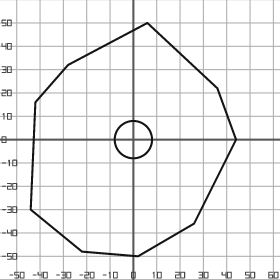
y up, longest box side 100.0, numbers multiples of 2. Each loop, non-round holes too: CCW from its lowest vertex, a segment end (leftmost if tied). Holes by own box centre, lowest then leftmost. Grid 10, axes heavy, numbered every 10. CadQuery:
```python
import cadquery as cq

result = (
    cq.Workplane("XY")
    .moveTo(2.0, -50.0)
    .lineTo(26.0, -36.0)
    .lineTo(44.0, 0.0)
    .lineTo(36.0, 22.0)
    .lineTo(6.0, 50.0)
    .lineTo(-28.0, 32.0)
    .lineTo(-42.0, 16.0)
    .lineTo(-44.0, -30.0)
    .lineTo(-22.0, -48.0)
    .close()
    .moveTo(0.0, 0.0)
    .circle(8.0)
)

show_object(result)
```